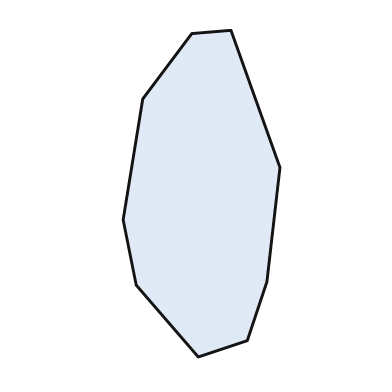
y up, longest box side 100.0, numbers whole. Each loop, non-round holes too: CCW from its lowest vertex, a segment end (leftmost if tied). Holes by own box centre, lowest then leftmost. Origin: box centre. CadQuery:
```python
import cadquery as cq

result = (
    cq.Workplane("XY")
    .moveTo(-1.0, -50.0)
    .lineTo(14.0, -45.0)
    .lineTo(20.0, -27.0)
    .lineTo(24.0, 8.0)
    .lineTo(9.0, 50.0)
    .lineTo(-3.0, 49.0)
    .lineTo(-18.0, 29.0)
    .lineTo(-24.0, -8.0)
    .lineTo(-20.0, -28.0)
    .close()
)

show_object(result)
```